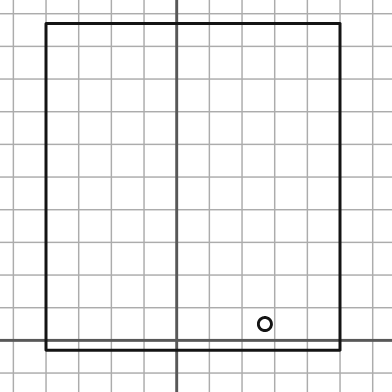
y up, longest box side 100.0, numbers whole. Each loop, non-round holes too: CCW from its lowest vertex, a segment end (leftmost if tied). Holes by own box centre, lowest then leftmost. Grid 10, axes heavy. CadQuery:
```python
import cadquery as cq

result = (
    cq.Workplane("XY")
    .moveTo(-40.0, -3.0)
    .lineTo(50.0, -3.0)
    .lineTo(50.0, 97.0)
    .lineTo(-40.0, 97.0)
    .close()
    .moveTo(27.0, 5.0)
    .circle(2.0)
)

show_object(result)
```